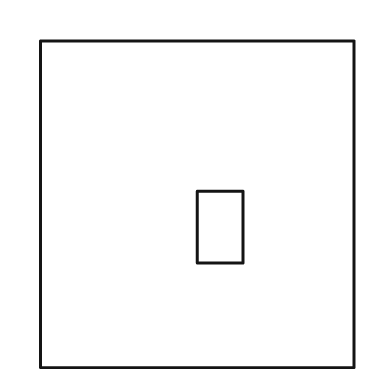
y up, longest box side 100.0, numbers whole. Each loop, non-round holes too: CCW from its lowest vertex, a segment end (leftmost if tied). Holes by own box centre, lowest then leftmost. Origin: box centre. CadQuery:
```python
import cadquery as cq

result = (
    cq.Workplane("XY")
    .moveTo(-48.0, -50.0)
    .lineTo(48.0, -50.0)
    .lineTo(48.0, 50.0)
    .lineTo(-48.0, 50.0)
    .close()
    .moveTo(0.0, -18.0)
    .lineTo(14.0, -18.0)
    .lineTo(14.0, 4.0)
    .lineTo(0.0, 4.0)
    .close()
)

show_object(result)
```